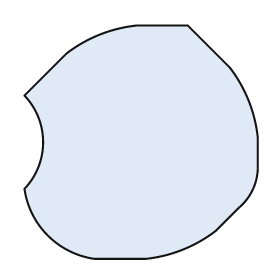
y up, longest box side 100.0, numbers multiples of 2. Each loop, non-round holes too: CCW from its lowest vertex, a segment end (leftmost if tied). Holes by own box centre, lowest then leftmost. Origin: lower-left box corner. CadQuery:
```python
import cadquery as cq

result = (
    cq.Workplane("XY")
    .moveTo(30.0, 0.0)
    .lineTo(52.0, 0.0)
    .threePointArc((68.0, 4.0), (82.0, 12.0))
    .lineTo(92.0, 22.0)
    .threePointArc((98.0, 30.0), (100.0, 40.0))
    .lineTo(100.0, 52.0)
    .threePointArc((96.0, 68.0), (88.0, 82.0))
    .lineTo(70.0, 100.0)
    .lineTo(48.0, 100.0)
    .threePointArc((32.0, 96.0), (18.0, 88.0))
    .lineTo(0.0, 70.0)
    .threePointArc((8.0, 50.0), (0.0, 30.0))
    .threePointArc((10.0, 10.0), (30.0, 0.0))
    .close()
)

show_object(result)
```